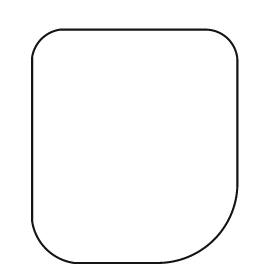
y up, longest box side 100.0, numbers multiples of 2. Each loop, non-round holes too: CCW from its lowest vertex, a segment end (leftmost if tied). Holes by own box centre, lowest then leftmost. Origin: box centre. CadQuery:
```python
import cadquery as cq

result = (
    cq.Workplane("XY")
    .moveTo(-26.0, -50.0)
    .lineTo(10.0, -50.0)
    .threePointArc((34.0, -40.0), (44.0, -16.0))
    .lineTo(44.0, 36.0)
    .threePointArc((40.0, 46.0), (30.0, 50.0))
    .lineTo(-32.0, 50.0)
    .threePointArc((-40.0, 46.0), (-44.0, 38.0))
    .lineTo(-44.0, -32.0)
    .threePointArc((-38.0, -44.0), (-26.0, -50.0))
    .close()
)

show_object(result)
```